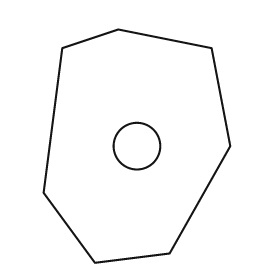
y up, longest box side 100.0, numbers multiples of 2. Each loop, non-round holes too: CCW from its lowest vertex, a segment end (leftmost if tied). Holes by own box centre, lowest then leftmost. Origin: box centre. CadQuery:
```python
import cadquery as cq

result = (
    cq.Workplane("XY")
    .moveTo(-18.0, -50.0)
    .lineTo(14.0, -46.0)
    .lineTo(40.0, 0.0)
    .lineTo(32.0, 42.0)
    .lineTo(-8.0, 50.0)
    .lineTo(-32.0, 42.0)
    .lineTo(-40.0, -20.0)
    .close()
    .moveTo(0.0, 0.0)
    .circle(10.0)
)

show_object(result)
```